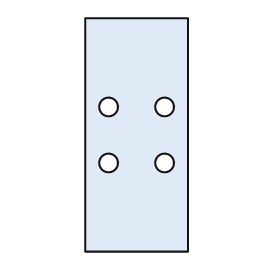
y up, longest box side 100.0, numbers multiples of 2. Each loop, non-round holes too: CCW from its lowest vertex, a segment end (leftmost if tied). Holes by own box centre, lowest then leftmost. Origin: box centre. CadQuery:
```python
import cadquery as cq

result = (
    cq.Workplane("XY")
    .moveTo(-22.0, -50.0)
    .lineTo(22.0, -50.0)
    .lineTo(22.0, 50.0)
    .lineTo(-22.0, 50.0)
    .close()
    .moveTo(-12.0, -12.0)
    .circle(4.0)
    .moveTo(12.0, -12.0)
    .circle(4.0)
    .moveTo(-12.0, 12.0)
    .circle(4.0)
    .moveTo(12.0, 12.0)
    .circle(4.0)
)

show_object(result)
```